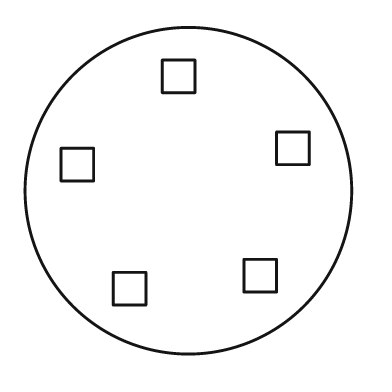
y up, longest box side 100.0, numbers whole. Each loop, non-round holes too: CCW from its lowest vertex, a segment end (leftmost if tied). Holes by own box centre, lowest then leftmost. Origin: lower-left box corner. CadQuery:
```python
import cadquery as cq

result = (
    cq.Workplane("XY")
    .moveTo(50.0, 50.0)
    .circle(50.0)
    .moveTo(27.0, 15.0)
    .lineTo(37.0, 15.0)
    .lineTo(37.0, 25.0)
    .lineTo(27.0, 25.0)
    .close()
    .moveTo(67.0, 19.0)
    .lineTo(77.0, 19.0)
    .lineTo(77.0, 29.0)
    .lineTo(67.0, 29.0)
    .close()
    .moveTo(11.0, 53.0)
    .lineTo(21.0, 53.0)
    .lineTo(21.0, 63.0)
    .lineTo(11.0, 63.0)
    .close()
    .moveTo(77.0, 58.0)
    .lineTo(87.0, 58.0)
    .lineTo(87.0, 68.0)
    .lineTo(77.0, 68.0)
    .close()
    .moveTo(42.0, 80.0)
    .lineTo(52.0, 80.0)
    .lineTo(52.0, 90.0)
    .lineTo(42.0, 90.0)
    .close()
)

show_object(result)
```